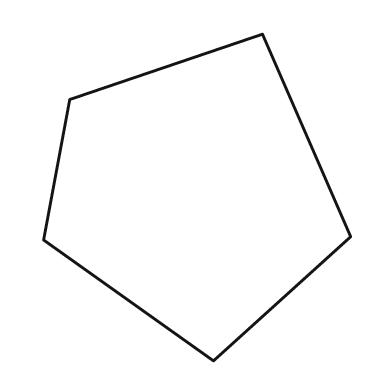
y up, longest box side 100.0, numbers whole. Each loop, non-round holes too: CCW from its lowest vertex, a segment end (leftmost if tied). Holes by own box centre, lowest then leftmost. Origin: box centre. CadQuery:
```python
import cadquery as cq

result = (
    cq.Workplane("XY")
    .moveTo(5.0, -50.0)
    .lineTo(47.0, -12.0)
    .lineTo(20.0, 50.0)
    .lineTo(-39.0, 30.0)
    .lineTo(-47.0, -13.0)
    .close()
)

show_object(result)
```